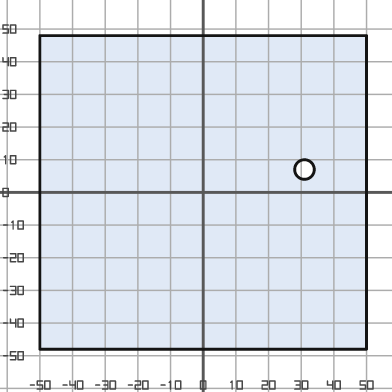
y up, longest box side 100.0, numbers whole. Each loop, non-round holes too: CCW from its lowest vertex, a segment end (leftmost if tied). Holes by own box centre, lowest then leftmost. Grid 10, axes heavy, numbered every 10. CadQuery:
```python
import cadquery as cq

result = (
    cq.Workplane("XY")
    .moveTo(-50.0, -48.0)
    .lineTo(50.0, -48.0)
    .lineTo(50.0, 48.0)
    .lineTo(-50.0, 48.0)
    .close()
    .moveTo(31.0, 7.0)
    .circle(3.0)
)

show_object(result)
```